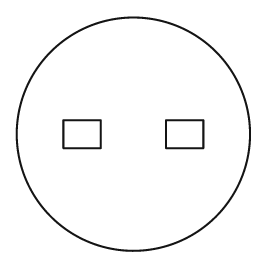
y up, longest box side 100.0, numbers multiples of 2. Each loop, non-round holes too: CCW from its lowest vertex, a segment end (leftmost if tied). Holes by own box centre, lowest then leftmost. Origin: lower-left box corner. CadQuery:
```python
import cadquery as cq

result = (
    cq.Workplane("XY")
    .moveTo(50.0, 50.0)
    .circle(50.0)
    .moveTo(20.0, 44.0)
    .lineTo(36.0, 44.0)
    .lineTo(36.0, 56.0)
    .lineTo(20.0, 56.0)
    .close()
    .moveTo(64.0, 44.0)
    .lineTo(80.0, 44.0)
    .lineTo(80.0, 56.0)
    .lineTo(64.0, 56.0)
    .close()
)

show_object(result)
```